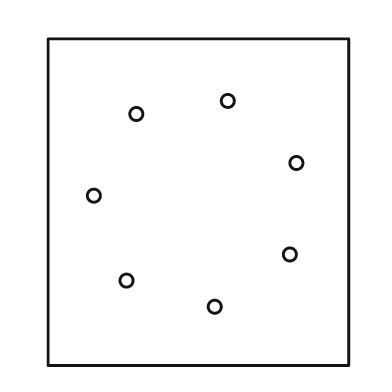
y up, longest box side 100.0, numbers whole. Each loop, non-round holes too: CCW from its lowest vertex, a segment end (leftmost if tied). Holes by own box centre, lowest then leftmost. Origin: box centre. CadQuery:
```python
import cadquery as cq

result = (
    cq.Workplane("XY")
    .moveTo(-46.0, -50.0)
    .lineTo(46.0, -50.0)
    .lineTo(46.0, 50.0)
    .lineTo(-46.0, 50.0)
    .close()
    .moveTo(5.0, -32.0)
    .circle(2.0)
    .moveTo(-22.0, -24.0)
    .circle(2.0)
    .moveTo(28.0, -16.0)
    .circle(2.0)
    .moveTo(-32.0, 2.0)
    .circle(2.0)
    .moveTo(30.0, 12.0)
    .circle(2.0)
    .moveTo(-19.0, 27.0)
    .circle(2.0)
    .moveTo(9.0, 31.0)
    .circle(2.0)
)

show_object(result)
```